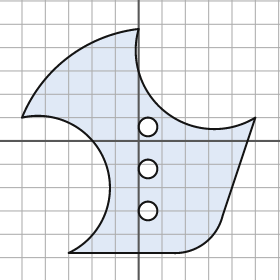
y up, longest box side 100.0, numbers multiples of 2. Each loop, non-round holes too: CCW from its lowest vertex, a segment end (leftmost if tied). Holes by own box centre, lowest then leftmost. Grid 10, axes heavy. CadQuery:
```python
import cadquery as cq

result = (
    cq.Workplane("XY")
    .moveTo(-30.0, -48.0)
    .lineTo(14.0, -48.0)
    .threePointArc((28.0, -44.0), (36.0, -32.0))
    .lineTo(50.0, 10.0)
    .threePointArc((12.0, 12.0), (0.0, 48.0))
    .threePointArc((-30.0, 36.0), (-50.0, 10.0))
    .threePointArc((-14.0, -10.0), (-30.0, -48.0))
    .close()
    .moveTo(4.0, -30.0)
    .circle(4.0)
    .moveTo(4.0, -12.0)
    .circle(4.0)
    .moveTo(4.0, 6.0)
    .circle(4.0)
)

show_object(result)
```